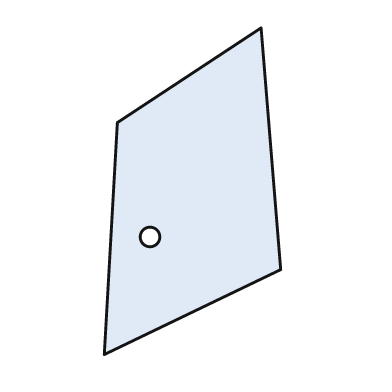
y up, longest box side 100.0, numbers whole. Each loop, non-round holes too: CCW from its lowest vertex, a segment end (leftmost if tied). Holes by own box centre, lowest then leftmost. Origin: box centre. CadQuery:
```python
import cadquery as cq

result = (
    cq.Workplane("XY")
    .moveTo(-27.0, -50.0)
    .lineTo(27.0, -24.0)
    .lineTo(21.0, 50.0)
    .lineTo(-23.0, 21.0)
    .close()
    .moveTo(-13.0, -14.0)
    .circle(3.0)
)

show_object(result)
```